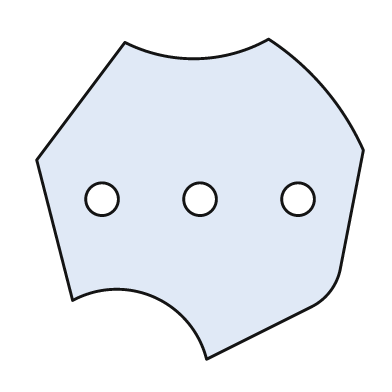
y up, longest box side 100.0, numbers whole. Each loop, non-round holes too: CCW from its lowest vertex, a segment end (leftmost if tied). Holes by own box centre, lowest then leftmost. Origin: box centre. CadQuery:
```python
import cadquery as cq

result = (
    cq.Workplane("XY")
    .moveTo(2.0, -49.0)
    .lineTo(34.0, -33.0)
    .threePointArc((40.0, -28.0), (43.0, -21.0))
    .lineTo(50.0, 15.0)
    .threePointArc((38.0, 34.0), (21.0, 49.0))
    .threePointArc((-1.0, 43.0), (-23.0, 48.0))
    .lineTo(-50.0, 12.0)
    .lineTo(-39.0, -31.0)
    .threePointArc((-14.0, -30.0), (2.0, -49.0))
    .close()
    .moveTo(-30.0, 0.0)
    .circle(5.0)
    .moveTo(0.0, 0.0)
    .circle(5.0)
    .moveTo(30.0, 0.0)
    .circle(5.0)
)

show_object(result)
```